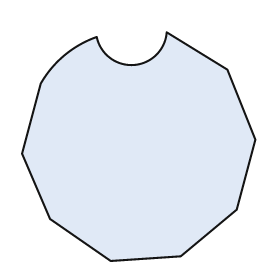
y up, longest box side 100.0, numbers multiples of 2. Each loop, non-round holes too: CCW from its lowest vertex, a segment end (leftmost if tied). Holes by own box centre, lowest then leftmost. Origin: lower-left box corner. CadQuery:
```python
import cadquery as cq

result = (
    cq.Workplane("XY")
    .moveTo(38.0, 0.0)
    .lineTo(68.0, 2.0)
    .lineTo(92.0, 22.0)
    .lineTo(100.0, 52.0)
    .lineTo(88.0, 82.0)
    .lineTo(62.0, 98.0)
    .threePointArc((48.0, 84.0), (32.0, 96.0))
    .threePointArc((18.0, 88.0), (8.0, 76.0))
    .lineTo(0.0, 46.0)
    .lineTo(12.0, 18.0)
    .close()
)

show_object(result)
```